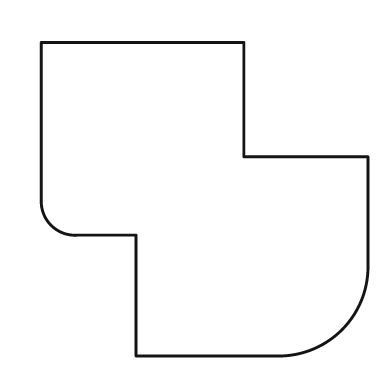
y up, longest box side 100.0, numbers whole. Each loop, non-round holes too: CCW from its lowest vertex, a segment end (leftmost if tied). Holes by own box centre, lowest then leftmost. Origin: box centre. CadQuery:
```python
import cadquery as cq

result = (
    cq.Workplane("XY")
    .moveTo(-21.0, -48.0)
    .lineTo(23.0, -48.0)
    .threePointArc((42.0, -40.0), (50.0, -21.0))
    .lineTo(50.0, 13.0)
    .lineTo(12.0, 13.0)
    .lineTo(12.0, 48.0)
    .lineTo(-50.0, 48.0)
    .lineTo(-50.0, 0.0)
    .threePointArc((-47.0, -8.0), (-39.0, -11.0))
    .lineTo(-21.0, -11.0)
    .close()
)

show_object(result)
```